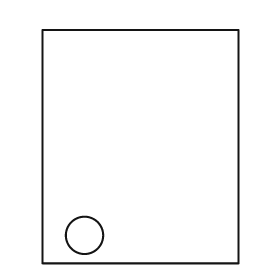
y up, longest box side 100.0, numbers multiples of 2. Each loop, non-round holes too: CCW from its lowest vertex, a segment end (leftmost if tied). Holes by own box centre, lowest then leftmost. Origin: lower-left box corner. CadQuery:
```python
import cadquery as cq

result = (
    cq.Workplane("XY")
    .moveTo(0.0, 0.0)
    .lineTo(84.0, 0.0)
    .lineTo(84.0, 100.0)
    .lineTo(0.0, 100.0)
    .close()
    .moveTo(18.0, 12.0)
    .circle(8.0)
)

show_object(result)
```